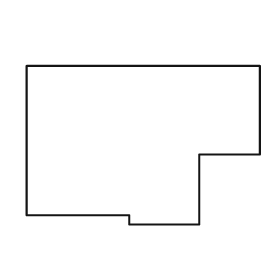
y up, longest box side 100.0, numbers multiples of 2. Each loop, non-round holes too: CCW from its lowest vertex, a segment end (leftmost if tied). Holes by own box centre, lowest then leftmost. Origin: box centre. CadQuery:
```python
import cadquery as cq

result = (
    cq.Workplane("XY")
    .moveTo(-6.0, -34.0)
    .lineTo(24.0, -34.0)
    .lineTo(24.0, -4.0)
    .lineTo(50.0, -4.0)
    .lineTo(50.0, 34.0)
    .lineTo(-50.0, 34.0)
    .lineTo(-50.0, -30.0)
    .lineTo(-6.0, -30.0)
    .close()
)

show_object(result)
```